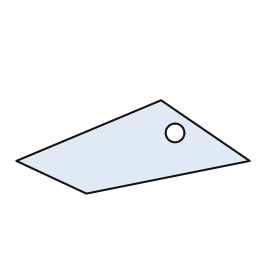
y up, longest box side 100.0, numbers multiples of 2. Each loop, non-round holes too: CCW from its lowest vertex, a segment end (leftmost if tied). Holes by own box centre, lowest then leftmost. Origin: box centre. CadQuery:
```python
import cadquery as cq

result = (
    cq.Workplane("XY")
    .moveTo(-20.0, -20.0)
    .lineTo(50.0, -6.0)
    .lineTo(12.0, 20.0)
    .lineTo(-50.0, -6.0)
    .close()
    .moveTo(18.0, 6.0)
    .circle(4.0)
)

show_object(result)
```